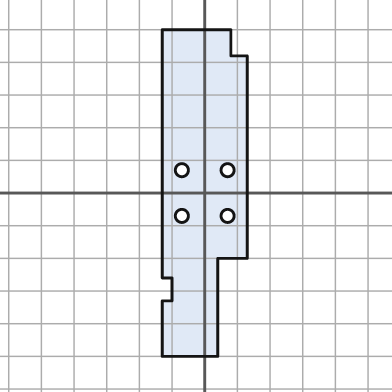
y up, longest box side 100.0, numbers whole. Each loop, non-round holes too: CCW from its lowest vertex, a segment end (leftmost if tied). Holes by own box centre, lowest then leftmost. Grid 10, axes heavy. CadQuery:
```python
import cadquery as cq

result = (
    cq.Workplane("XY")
    .moveTo(-13.0, -50.0)
    .lineTo(4.0, -50.0)
    .lineTo(4.0, -20.0)
    .lineTo(13.0, -20.0)
    .lineTo(13.0, 42.0)
    .lineTo(8.0, 42.0)
    .lineTo(8.0, 50.0)
    .lineTo(-13.0, 50.0)
    .lineTo(-13.0, -26.0)
    .lineTo(-10.0, -26.0)
    .lineTo(-10.0, -33.0)
    .lineTo(-13.0, -33.0)
    .close()
    .moveTo(-7.0, -7.0)
    .circle(2.0)
    .moveTo(7.0, -7.0)
    .circle(2.0)
    .moveTo(-7.0, 7.0)
    .circle(2.0)
    .moveTo(7.0, 7.0)
    .circle(2.0)
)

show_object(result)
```